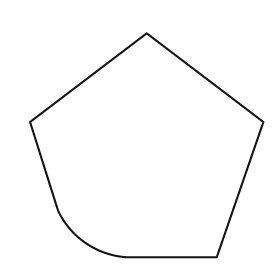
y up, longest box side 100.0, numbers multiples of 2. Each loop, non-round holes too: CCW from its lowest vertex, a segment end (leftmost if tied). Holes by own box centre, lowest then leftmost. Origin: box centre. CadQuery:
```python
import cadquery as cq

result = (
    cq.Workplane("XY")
    .moveTo(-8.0, -48.0)
    .lineTo(30.0, -48.0)
    .lineTo(50.0, 10.0)
    .lineTo(0.0, 48.0)
    .lineTo(-50.0, 10.0)
    .lineTo(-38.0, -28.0)
    .threePointArc((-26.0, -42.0), (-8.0, -48.0))
    .close()
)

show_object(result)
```